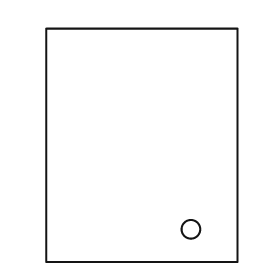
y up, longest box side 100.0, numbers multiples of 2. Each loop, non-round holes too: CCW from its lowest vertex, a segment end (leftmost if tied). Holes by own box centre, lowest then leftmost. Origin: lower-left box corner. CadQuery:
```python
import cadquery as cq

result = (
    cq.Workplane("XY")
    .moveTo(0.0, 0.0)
    .lineTo(82.0, 0.0)
    .lineTo(82.0, 100.0)
    .lineTo(0.0, 100.0)
    .close()
    .moveTo(62.0, 14.0)
    .circle(4.0)
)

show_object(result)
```